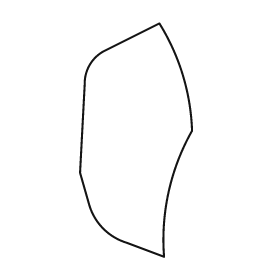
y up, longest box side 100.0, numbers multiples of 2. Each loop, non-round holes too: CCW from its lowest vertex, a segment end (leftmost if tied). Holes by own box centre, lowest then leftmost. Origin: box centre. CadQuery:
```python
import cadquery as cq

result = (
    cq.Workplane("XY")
    .moveTo(12.0, -50.0)
    .threePointArc((14.0, -22.0), (24.0, 4.0))
    .threePointArc((20.0, 28.0), (10.0, 50.0))
    .lineTo(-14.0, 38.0)
    .threePointArc((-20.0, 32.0), (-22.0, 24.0))
    .lineTo(-24.0, -14.0)
    .lineTo(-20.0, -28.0)
    .threePointArc((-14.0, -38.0), (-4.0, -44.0))
    .close()
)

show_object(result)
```